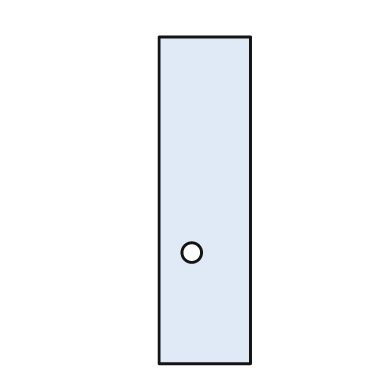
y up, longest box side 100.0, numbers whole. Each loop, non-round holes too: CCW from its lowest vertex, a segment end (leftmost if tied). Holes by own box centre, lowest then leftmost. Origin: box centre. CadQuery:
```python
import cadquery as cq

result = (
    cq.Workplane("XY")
    .moveTo(-14.0, -50.0)
    .lineTo(14.0, -50.0)
    .lineTo(14.0, 50.0)
    .lineTo(-14.0, 50.0)
    .close()
    .moveTo(-4.0, -16.0)
    .circle(3.0)
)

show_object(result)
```